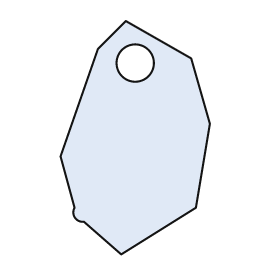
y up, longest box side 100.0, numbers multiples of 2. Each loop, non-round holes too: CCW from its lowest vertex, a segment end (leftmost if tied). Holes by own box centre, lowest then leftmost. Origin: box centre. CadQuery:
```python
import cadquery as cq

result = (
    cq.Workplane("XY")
    .moveTo(-6.0, -50.0)
    .lineTo(26.0, -30.0)
    .lineTo(32.0, 6.0)
    .lineTo(24.0, 34.0)
    .lineTo(-4.0, 50.0)
    .lineTo(-16.0, 38.0)
    .lineTo(-32.0, -8.0)
    .lineTo(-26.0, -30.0)
    .threePointArc((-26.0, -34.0), (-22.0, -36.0))
    .close()
    .moveTo(0.0, 32.0)
    .circle(8.0)
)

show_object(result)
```